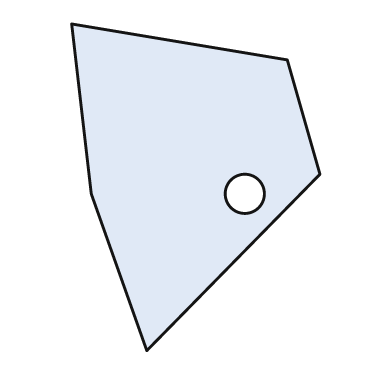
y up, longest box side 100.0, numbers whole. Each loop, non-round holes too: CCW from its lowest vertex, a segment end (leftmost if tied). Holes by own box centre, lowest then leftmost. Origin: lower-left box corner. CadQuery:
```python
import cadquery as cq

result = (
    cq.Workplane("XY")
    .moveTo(23.0, 0.0)
    .lineTo(76.0, 54.0)
    .lineTo(66.0, 89.0)
    .lineTo(0.0, 100.0)
    .lineTo(6.0, 48.0)
    .close()
    .moveTo(53.0, 48.0)
    .circle(6.0)
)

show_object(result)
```